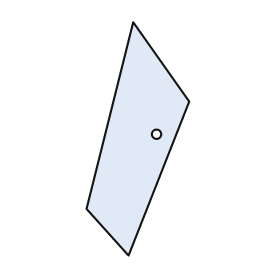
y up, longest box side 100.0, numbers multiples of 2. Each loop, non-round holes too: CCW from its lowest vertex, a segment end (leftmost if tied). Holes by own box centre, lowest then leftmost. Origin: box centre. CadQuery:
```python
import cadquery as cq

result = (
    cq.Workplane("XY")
    .moveTo(-4.0, -50.0)
    .lineTo(22.0, 16.0)
    .lineTo(-2.0, 50.0)
    .lineTo(-22.0, -30.0)
    .close()
    .moveTo(8.0, 2.0)
    .circle(2.0)
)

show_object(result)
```